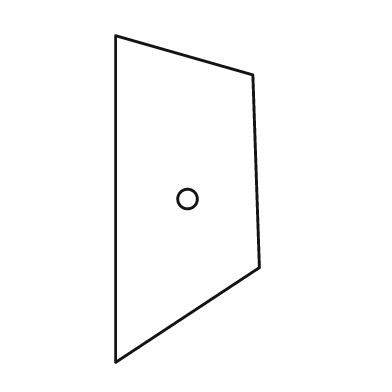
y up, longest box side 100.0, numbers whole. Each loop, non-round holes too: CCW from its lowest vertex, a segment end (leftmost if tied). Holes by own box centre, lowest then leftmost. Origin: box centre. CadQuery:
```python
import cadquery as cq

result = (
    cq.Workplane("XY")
    .moveTo(-22.0, -50.0)
    .lineTo(22.0, -21.0)
    .lineTo(20.0, 38.0)
    .lineTo(-22.0, 50.0)
    .close()
    .moveTo(0.0, 0.0)
    .circle(3.0)
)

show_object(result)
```